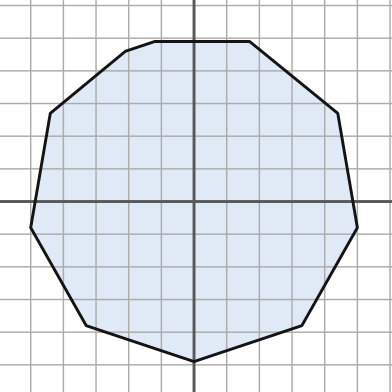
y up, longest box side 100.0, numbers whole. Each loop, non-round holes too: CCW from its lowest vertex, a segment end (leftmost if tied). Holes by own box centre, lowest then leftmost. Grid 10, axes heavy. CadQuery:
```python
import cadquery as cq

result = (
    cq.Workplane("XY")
    .moveTo(0.0, -49.0)
    .lineTo(33.0, -38.0)
    .lineTo(50.0, -8.0)
    .lineTo(44.0, 27.0)
    .lineTo(17.0, 49.0)
    .lineTo(-12.0, 49.0)
    .lineTo(-21.0, 46.0)
    .lineTo(-44.0, 27.0)
    .lineTo(-50.0, -8.0)
    .lineTo(-33.0, -38.0)
    .close()
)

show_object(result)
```